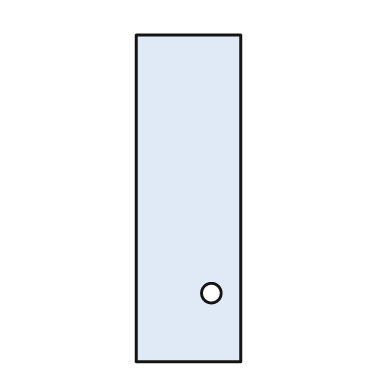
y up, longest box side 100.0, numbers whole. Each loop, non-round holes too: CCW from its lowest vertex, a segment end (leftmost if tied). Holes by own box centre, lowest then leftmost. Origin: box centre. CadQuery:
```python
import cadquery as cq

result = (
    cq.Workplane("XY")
    .moveTo(-16.0, -50.0)
    .lineTo(16.0, -50.0)
    .lineTo(16.0, 50.0)
    .lineTo(-16.0, 50.0)
    .close()
    .moveTo(7.0, -29.0)
    .circle(3.0)
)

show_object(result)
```